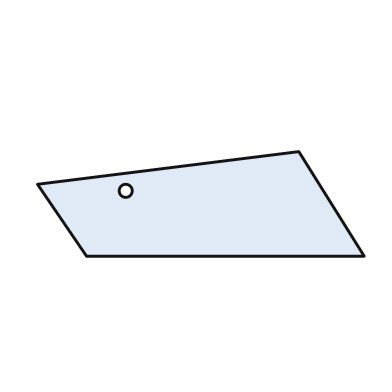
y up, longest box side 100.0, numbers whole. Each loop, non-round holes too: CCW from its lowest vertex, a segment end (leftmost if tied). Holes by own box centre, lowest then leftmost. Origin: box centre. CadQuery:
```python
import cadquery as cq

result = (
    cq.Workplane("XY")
    .moveTo(-35.0, -16.0)
    .lineTo(50.0, -16.0)
    .lineTo(30.0, 16.0)
    .lineTo(-50.0, 6.0)
    .close()
    .moveTo(-23.0, 4.0)
    .circle(2.0)
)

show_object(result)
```